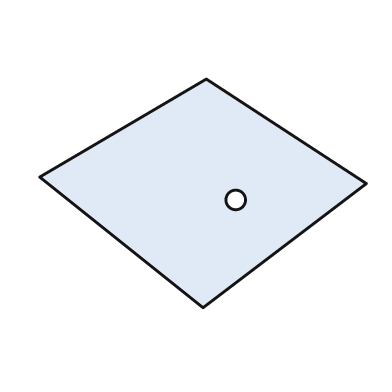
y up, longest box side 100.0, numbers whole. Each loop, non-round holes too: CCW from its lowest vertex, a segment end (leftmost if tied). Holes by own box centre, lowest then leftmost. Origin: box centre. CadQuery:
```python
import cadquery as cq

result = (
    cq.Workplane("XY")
    .moveTo(0.0, -35.0)
    .lineTo(50.0, 3.0)
    .lineTo(1.0, 35.0)
    .lineTo(-50.0, 5.0)
    .close()
    .moveTo(10.0, -2.0)
    .circle(3.0)
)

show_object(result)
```